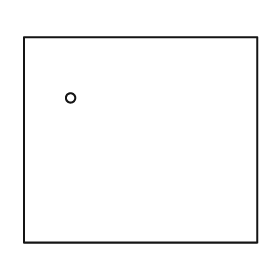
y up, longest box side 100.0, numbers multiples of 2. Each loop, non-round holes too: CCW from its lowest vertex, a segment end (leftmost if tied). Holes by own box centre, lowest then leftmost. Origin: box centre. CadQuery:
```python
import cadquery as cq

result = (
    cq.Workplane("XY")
    .moveTo(-50.0, -44.0)
    .lineTo(50.0, -44.0)
    .lineTo(50.0, 44.0)
    .lineTo(-50.0, 44.0)
    .close()
    .moveTo(-30.0, 18.0)
    .circle(2.0)
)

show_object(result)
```